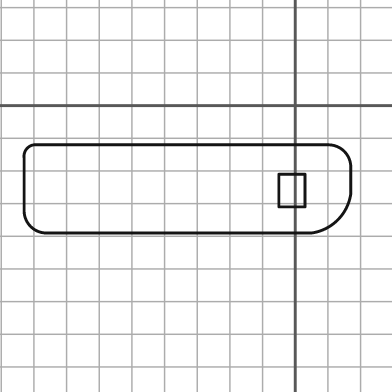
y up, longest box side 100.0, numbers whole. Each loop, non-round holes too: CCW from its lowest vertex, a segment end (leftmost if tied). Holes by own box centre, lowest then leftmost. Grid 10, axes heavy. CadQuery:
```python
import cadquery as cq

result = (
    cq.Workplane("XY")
    .moveTo(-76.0, -39.0)
    .lineTo(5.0, -39.0)
    .threePointArc((13.0, -35.0), (17.0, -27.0))
    .lineTo(17.0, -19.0)
    .threePointArc((15.0, -14.0), (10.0, -12.0))
    .lineTo(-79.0, -12.0)
    .threePointArc((-82.0, -13.0), (-83.0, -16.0))
    .lineTo(-83.0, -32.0)
    .threePointArc((-81.0, -37.0), (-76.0, -39.0))
    .close()
    .moveTo(-5.0, -31.0)
    .lineTo(3.0, -31.0)
    .lineTo(3.0, -21.0)
    .lineTo(-5.0, -21.0)
    .close()
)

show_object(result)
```